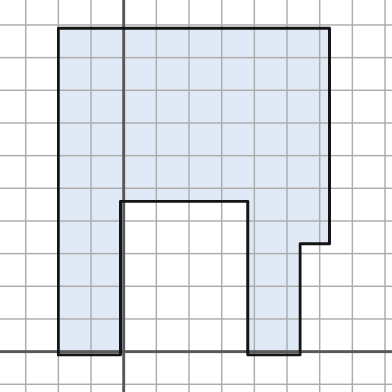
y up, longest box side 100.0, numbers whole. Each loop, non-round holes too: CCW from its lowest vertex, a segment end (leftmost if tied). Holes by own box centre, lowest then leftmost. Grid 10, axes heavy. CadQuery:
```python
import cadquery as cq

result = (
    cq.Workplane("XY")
    .moveTo(-20.0, -1.0)
    .lineTo(-1.0, -1.0)
    .lineTo(-1.0, 46.0)
    .lineTo(38.0, 46.0)
    .lineTo(38.0, -1.0)
    .lineTo(54.0, -1.0)
    .lineTo(54.0, 33.0)
    .lineTo(63.0, 33.0)
    .lineTo(63.0, 99.0)
    .lineTo(-20.0, 99.0)
    .close()
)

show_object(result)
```